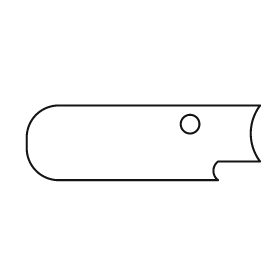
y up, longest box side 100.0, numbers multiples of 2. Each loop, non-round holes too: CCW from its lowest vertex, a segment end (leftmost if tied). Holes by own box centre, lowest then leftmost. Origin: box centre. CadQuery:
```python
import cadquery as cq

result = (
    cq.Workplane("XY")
    .moveTo(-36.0, -16.0)
    .lineTo(32.0, -16.0)
    .threePointArc((30.0, -12.0), (32.0, -8.0))
    .lineTo(50.0, -8.0)
    .threePointArc((46.0, 4.0), (50.0, 16.0))
    .lineTo(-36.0, 16.0)
    .threePointArc((-46.0, 12.0), (-50.0, 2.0))
    .lineTo(-50.0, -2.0)
    .threePointArc((-46.0, -12.0), (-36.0, -16.0))
    .close()
    .moveTo(20.0, 8.0)
    .circle(4.0)
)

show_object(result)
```